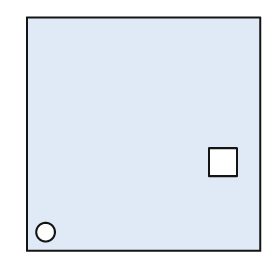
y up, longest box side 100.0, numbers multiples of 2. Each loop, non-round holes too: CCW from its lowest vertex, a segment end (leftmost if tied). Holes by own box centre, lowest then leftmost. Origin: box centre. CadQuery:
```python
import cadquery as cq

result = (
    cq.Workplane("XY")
    .moveTo(-50.0, -50.0)
    .lineTo(50.0, -50.0)
    .lineTo(50.0, 50.0)
    .lineTo(-50.0, 50.0)
    .close()
    .moveTo(-42.0, -42.0)
    .circle(4.0)
    .moveTo(28.0, -18.0)
    .lineTo(40.0, -18.0)
    .lineTo(40.0, -6.0)
    .lineTo(28.0, -6.0)
    .close()
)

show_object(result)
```